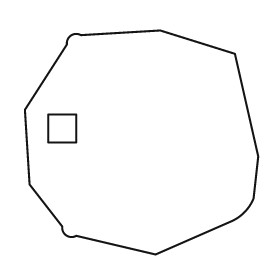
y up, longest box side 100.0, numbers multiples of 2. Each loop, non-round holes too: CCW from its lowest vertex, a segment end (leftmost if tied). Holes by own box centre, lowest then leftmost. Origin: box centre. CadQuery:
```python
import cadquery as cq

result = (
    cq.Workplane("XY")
    .moveTo(6.0, -48.0)
    .lineTo(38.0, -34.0)
    .threePointArc((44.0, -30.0), (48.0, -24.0))
    .lineTo(50.0, -6.0)
    .lineTo(40.0, 38.0)
    .lineTo(8.0, 48.0)
    .lineTo(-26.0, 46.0)
    .threePointArc((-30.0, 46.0), (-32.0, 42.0))
    .lineTo(-50.0, 14.0)
    .lineTo(-48.0, -18.0)
    .lineTo(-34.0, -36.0)
    .threePointArc((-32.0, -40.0), (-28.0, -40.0))
    .close()
    .moveTo(-40.0, 0.0)
    .lineTo(-28.0, 0.0)
    .lineTo(-28.0, 12.0)
    .lineTo(-40.0, 12.0)
    .close()
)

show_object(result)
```